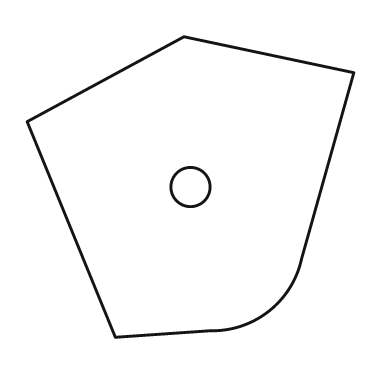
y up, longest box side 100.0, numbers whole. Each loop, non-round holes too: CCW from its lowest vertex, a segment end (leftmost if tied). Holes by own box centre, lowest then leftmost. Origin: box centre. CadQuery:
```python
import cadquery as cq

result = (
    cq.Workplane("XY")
    .moveTo(-23.0, -46.0)
    .lineTo(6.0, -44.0)
    .threePointArc((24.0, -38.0), (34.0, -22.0))
    .lineTo(50.0, 35.0)
    .lineTo(-2.0, 46.0)
    .lineTo(-50.0, 20.0)
    .close()
    .moveTo(0.0, 0.0)
    .circle(6.0)
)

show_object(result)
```